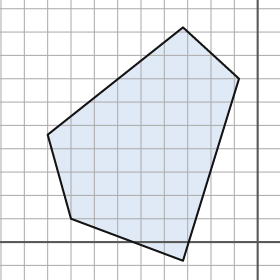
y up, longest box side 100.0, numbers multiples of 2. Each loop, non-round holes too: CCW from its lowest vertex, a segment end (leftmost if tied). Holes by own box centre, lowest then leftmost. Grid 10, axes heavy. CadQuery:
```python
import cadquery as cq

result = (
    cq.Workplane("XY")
    .moveTo(-32.0, -8.0)
    .lineTo(-8.0, 70.0)
    .lineTo(-32.0, 92.0)
    .lineTo(-90.0, 46.0)
    .lineTo(-80.0, 10.0)
    .close()
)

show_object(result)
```